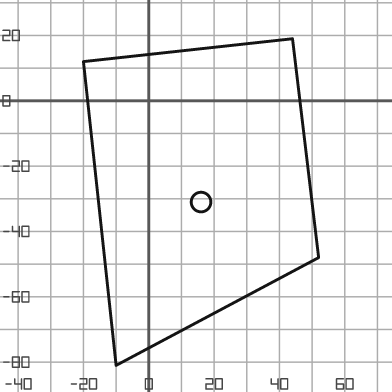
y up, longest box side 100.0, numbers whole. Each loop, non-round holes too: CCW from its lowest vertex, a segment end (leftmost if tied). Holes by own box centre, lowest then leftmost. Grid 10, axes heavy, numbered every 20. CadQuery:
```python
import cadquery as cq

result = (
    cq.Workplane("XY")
    .moveTo(-10.0, -81.0)
    .lineTo(52.0, -48.0)
    .lineTo(44.0, 19.0)
    .lineTo(-20.0, 12.0)
    .close()
    .moveTo(16.0, -31.0)
    .circle(3.0)
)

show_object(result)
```